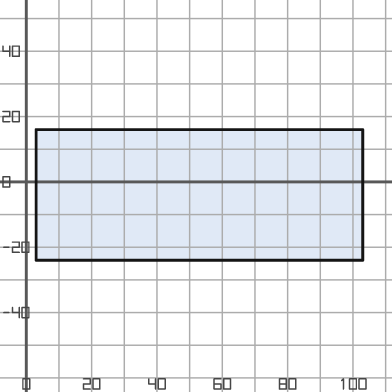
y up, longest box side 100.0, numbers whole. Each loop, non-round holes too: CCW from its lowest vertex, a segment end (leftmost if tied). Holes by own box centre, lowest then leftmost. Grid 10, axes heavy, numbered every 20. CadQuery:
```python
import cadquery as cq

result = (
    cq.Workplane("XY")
    .moveTo(3.0, -24.0)
    .lineTo(103.0, -24.0)
    .lineTo(103.0, 16.0)
    .lineTo(3.0, 16.0)
    .close()
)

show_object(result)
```